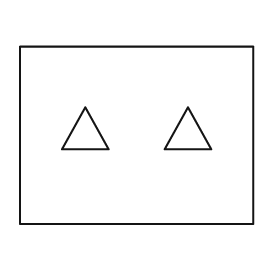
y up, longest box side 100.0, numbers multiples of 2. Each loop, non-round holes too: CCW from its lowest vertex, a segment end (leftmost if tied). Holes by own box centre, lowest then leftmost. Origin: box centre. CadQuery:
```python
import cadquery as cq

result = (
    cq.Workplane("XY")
    .moveTo(-50.0, -38.0)
    .lineTo(50.0, -38.0)
    .lineTo(50.0, 38.0)
    .lineTo(-50.0, 38.0)
    .close()
    .moveTo(-32.0, -6.0)
    .lineTo(-12.0, -6.0)
    .lineTo(-22.0, 12.0)
    .close()
    .moveTo(12.0, -6.0)
    .lineTo(32.0, -6.0)
    .lineTo(22.0, 12.0)
    .close()
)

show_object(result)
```